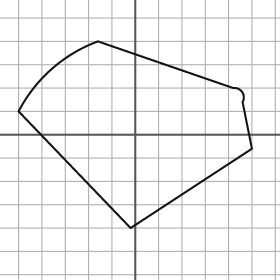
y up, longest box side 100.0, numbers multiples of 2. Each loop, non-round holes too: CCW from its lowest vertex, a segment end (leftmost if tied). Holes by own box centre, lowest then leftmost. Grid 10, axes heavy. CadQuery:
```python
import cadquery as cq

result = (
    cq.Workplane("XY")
    .moveTo(-2.0, -40.0)
    .lineTo(50.0, -6.0)
    .lineTo(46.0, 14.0)
    .threePointArc((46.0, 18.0), (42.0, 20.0))
    .lineTo(-16.0, 40.0)
    .threePointArc((-36.0, 28.0), (-50.0, 10.0))
    .close()
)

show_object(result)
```